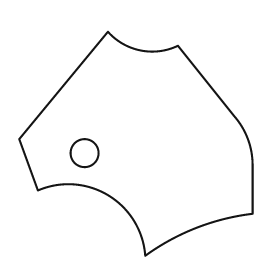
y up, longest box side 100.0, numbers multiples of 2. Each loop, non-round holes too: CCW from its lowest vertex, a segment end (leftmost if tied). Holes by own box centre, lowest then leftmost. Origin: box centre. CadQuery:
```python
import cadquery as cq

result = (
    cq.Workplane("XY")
    .moveTo(4.0, -48.0)
    .threePointArc((26.0, -36.0), (50.0, -30.0))
    .lineTo(50.0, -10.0)
    .threePointArc((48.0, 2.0), (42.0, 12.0))
    .lineTo(18.0, 42.0)
    .threePointArc((2.0, 40.0), (-12.0, 48.0))
    .lineTo(-50.0, 2.0)
    .lineTo(-42.0, -20.0)
    .threePointArc((-12.0, -22.0), (4.0, -48.0))
    .close()
    .moveTo(-22.0, -4.0)
    .circle(6.0)
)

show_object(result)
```